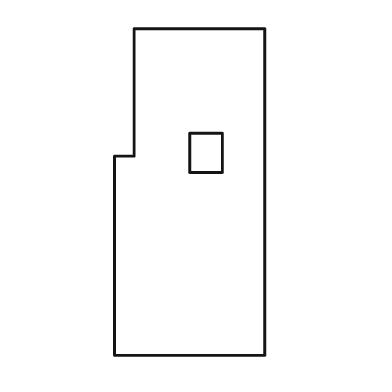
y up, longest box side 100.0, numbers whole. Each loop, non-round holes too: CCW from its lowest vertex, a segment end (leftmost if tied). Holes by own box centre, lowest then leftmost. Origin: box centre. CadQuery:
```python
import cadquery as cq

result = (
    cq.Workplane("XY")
    .moveTo(-23.0, -50.0)
    .lineTo(23.0, -50.0)
    .lineTo(23.0, 50.0)
    .lineTo(-17.0, 50.0)
    .lineTo(-17.0, 11.0)
    .lineTo(-23.0, 11.0)
    .close()
    .moveTo(0.0, 6.0)
    .lineTo(10.0, 6.0)
    .lineTo(10.0, 18.0)
    .lineTo(0.0, 18.0)
    .close()
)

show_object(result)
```